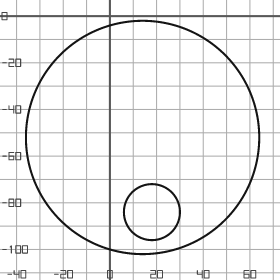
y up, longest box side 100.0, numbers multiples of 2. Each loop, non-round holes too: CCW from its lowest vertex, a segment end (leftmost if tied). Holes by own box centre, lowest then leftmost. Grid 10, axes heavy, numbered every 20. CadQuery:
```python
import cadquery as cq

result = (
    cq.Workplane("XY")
    .moveTo(14.0, -52.0)
    .circle(50.0)
    .moveTo(18.0, -84.0)
    .circle(12.0)
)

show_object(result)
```